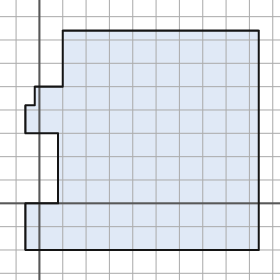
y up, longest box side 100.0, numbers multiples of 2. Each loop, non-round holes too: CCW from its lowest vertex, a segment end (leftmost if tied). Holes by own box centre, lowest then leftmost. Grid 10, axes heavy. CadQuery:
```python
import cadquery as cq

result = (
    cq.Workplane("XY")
    .moveTo(-6.0, -20.0)
    .lineTo(94.0, -20.0)
    .lineTo(94.0, 74.0)
    .lineTo(10.0, 74.0)
    .lineTo(10.0, 50.0)
    .lineTo(-2.0, 50.0)
    .lineTo(-2.0, 42.0)
    .lineTo(-6.0, 42.0)
    .lineTo(-6.0, 30.0)
    .lineTo(8.0, 30.0)
    .lineTo(8.0, 0.0)
    .lineTo(-6.0, 0.0)
    .close()
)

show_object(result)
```